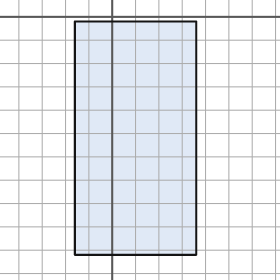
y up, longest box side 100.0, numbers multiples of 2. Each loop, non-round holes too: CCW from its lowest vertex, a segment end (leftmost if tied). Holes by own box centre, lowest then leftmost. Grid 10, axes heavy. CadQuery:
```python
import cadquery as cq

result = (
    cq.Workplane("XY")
    .moveTo(-16.0, -102.0)
    .lineTo(36.0, -102.0)
    .lineTo(36.0, -2.0)
    .lineTo(-16.0, -2.0)
    .close()
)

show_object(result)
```